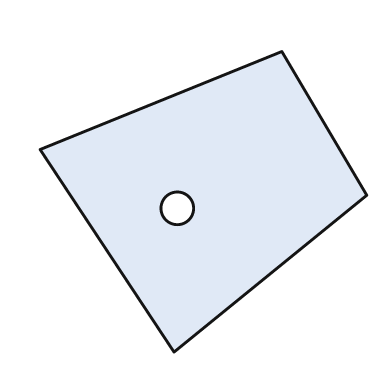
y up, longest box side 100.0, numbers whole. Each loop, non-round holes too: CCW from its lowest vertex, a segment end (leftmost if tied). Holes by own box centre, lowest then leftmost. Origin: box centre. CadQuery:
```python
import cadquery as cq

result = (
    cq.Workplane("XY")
    .moveTo(-9.0, -46.0)
    .lineTo(50.0, 2.0)
    .lineTo(24.0, 46.0)
    .lineTo(-50.0, 16.0)
    .close()
    .moveTo(-8.0, -2.0)
    .circle(5.0)
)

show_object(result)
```